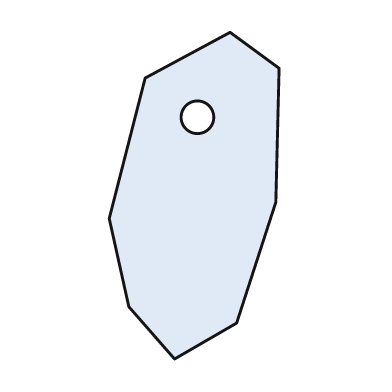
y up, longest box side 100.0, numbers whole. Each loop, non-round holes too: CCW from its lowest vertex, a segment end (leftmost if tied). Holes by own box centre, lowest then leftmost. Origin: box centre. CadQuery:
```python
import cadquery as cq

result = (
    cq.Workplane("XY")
    .moveTo(-6.0, -50.0)
    .lineTo(13.0, -39.0)
    .lineTo(25.0, -2.0)
    .lineTo(26.0, 39.0)
    .lineTo(11.0, 50.0)
    .lineTo(-15.0, 36.0)
    .lineTo(-26.0, -7.0)
    .lineTo(-20.0, -34.0)
    .close()
    .moveTo(1.0, 24.0)
    .circle(5.0)
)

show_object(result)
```